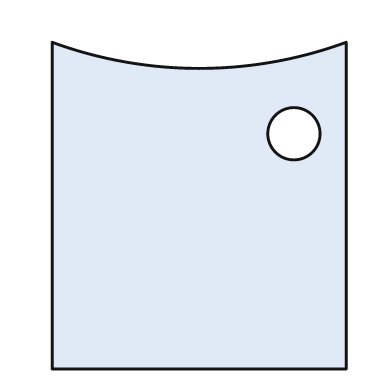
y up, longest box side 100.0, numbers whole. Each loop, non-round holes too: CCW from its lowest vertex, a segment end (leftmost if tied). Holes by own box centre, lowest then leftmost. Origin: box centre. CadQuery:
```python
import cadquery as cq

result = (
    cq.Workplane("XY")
    .moveTo(-45.0, -50.0)
    .lineTo(45.0, -50.0)
    .lineTo(45.0, 50.0)
    .threePointArc((0.0, 42.0), (-45.0, 50.0))
    .close()
    .moveTo(29.0, 22.0)
    .circle(8.0)
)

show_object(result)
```